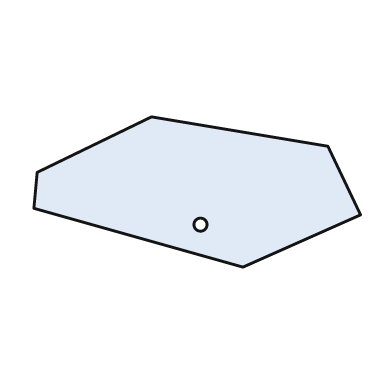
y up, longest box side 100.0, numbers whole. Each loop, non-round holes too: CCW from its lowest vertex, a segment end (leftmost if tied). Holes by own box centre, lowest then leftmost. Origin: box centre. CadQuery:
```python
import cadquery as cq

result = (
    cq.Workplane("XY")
    .moveTo(14.0, -23.0)
    .lineTo(50.0, -7.0)
    .lineTo(40.0, 14.0)
    .lineTo(-14.0, 23.0)
    .lineTo(-49.0, 6.0)
    .lineTo(-50.0, -5.0)
    .close()
    .moveTo(1.0, -10.0)
    .circle(2.0)
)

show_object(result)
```